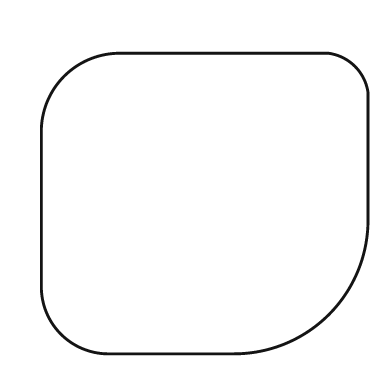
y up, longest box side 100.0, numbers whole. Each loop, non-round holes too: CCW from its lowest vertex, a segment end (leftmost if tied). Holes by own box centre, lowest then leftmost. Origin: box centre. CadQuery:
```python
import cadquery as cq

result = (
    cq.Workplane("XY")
    .moveTo(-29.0, -46.0)
    .lineTo(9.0, -46.0)
    .threePointArc((38.0, -34.0), (50.0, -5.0))
    .lineTo(50.0, 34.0)
    .threePointArc((46.0, 42.0), (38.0, 46.0))
    .lineTo(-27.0, 46.0)
    .threePointArc((-43.0, 39.0), (-50.0, 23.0))
    .lineTo(-50.0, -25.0)
    .threePointArc((-44.0, -40.0), (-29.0, -46.0))
    .close()
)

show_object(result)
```